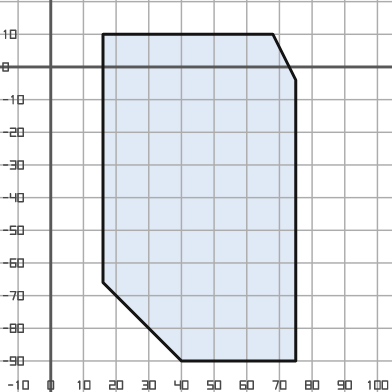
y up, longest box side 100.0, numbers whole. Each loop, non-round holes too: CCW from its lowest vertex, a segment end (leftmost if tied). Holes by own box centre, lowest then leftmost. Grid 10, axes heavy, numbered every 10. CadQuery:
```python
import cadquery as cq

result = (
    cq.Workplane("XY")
    .moveTo(40.0, -90.0)
    .lineTo(75.0, -90.0)
    .lineTo(75.0, -4.0)
    .lineTo(68.0, 10.0)
    .lineTo(16.0, 10.0)
    .lineTo(16.0, -66.0)
    .close()
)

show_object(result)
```